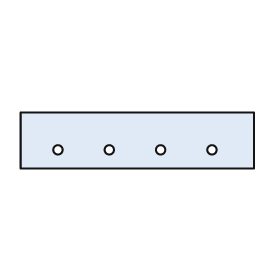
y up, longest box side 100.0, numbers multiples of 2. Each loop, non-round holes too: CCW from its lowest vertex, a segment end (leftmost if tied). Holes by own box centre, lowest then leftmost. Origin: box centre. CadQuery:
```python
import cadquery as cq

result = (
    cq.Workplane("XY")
    .moveTo(-50.0, -12.0)
    .lineTo(50.0, -12.0)
    .lineTo(50.0, 12.0)
    .lineTo(-50.0, 12.0)
    .close()
    .moveTo(-34.0, -4.0)
    .circle(2.0)
    .moveTo(-12.0, -4.0)
    .circle(2.0)
    .moveTo(10.0, -4.0)
    .circle(2.0)
    .moveTo(32.0, -4.0)
    .circle(2.0)
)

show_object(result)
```